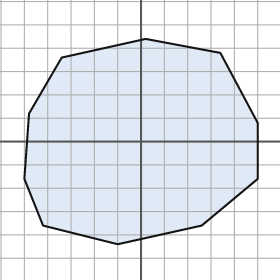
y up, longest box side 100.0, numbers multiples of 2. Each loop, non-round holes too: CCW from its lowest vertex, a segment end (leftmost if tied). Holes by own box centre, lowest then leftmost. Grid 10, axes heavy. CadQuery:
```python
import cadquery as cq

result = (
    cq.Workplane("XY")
    .moveTo(-10.0, -44.0)
    .lineTo(26.0, -36.0)
    .lineTo(50.0, -16.0)
    .lineTo(50.0, 8.0)
    .lineTo(34.0, 38.0)
    .lineTo(2.0, 44.0)
    .lineTo(-34.0, 36.0)
    .lineTo(-48.0, 12.0)
    .lineTo(-50.0, -16.0)
    .lineTo(-42.0, -36.0)
    .close()
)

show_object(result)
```